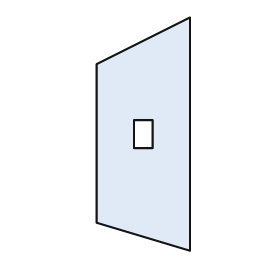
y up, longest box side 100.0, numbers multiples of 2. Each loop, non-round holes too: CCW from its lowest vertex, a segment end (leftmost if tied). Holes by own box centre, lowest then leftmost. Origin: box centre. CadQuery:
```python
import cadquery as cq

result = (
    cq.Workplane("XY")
    .moveTo(20.0, -50.0)
    .lineTo(20.0, 50.0)
    .lineTo(-20.0, 30.0)
    .lineTo(-20.0, -38.0)
    .close()
    .moveTo(-4.0, -6.0)
    .lineTo(4.0, -6.0)
    .lineTo(4.0, 6.0)
    .lineTo(-4.0, 6.0)
    .close()
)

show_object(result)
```